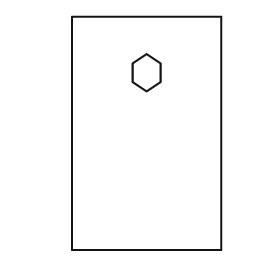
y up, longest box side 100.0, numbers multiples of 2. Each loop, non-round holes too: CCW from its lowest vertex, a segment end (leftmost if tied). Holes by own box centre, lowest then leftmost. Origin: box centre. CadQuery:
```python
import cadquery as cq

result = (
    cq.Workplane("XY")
    .moveTo(-32.0, -50.0)
    .lineTo(32.0, -50.0)
    .lineTo(32.0, 50.0)
    .lineTo(-32.0, 50.0)
    .close()
    .moveTo(0.0, 18.0)
    .lineTo(6.0, 22.0)
    .lineTo(6.0, 30.0)
    .lineTo(0.0, 34.0)
    .lineTo(-6.0, 30.0)
    .lineTo(-6.0, 22.0)
    .close()
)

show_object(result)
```